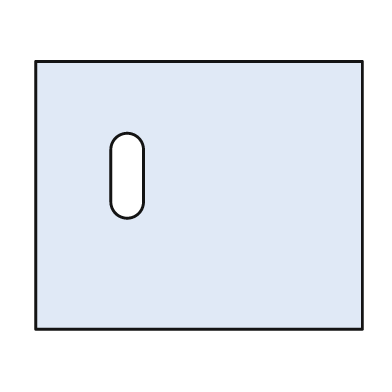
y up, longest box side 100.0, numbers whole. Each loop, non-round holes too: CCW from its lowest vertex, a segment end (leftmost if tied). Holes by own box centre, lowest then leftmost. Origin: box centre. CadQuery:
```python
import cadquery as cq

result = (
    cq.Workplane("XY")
    .moveTo(-50.0, -41.0)
    .lineTo(50.0, -41.0)
    .lineTo(50.0, 41.0)
    .lineTo(-50.0, 41.0)
    .close()
    .moveTo(-27.0, -2.0)
    .threePointArc((-22.0, -7.0), (-17.0, -2.0))
    .lineTo(-17.0, 14.0)
    .threePointArc((-22.0, 19.0), (-27.0, 14.0))
    .close()
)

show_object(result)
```